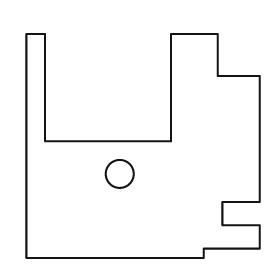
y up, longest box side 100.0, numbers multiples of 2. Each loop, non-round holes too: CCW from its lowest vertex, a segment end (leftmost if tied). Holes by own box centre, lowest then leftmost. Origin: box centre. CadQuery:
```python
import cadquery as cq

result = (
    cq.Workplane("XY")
    .moveTo(-50.0, -48.0)
    .lineTo(26.0, -48.0)
    .lineTo(26.0, -44.0)
    .lineTo(50.0, -44.0)
    .lineTo(50.0, -34.0)
    .lineTo(34.0, -34.0)
    .lineTo(34.0, -24.0)
    .lineTo(50.0, -24.0)
    .lineTo(50.0, 30.0)
    .lineTo(32.0, 30.0)
    .lineTo(32.0, 48.0)
    .lineTo(12.0, 48.0)
    .lineTo(12.0, 2.0)
    .lineTo(-42.0, 2.0)
    .lineTo(-42.0, 48.0)
    .lineTo(-50.0, 48.0)
    .close()
    .moveTo(-10.0, -12.0)
    .circle(6.0)
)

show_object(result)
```